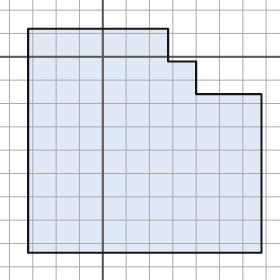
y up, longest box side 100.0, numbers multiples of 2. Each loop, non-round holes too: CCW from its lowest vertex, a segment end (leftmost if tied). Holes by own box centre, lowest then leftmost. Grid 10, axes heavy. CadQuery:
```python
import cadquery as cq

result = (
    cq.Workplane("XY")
    .moveTo(-32.0, -84.0)
    .lineTo(68.0, -84.0)
    .lineTo(68.0, -16.0)
    .lineTo(40.0, -16.0)
    .lineTo(40.0, -2.0)
    .lineTo(28.0, -2.0)
    .lineTo(28.0, 12.0)
    .lineTo(-32.0, 12.0)
    .close()
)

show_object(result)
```